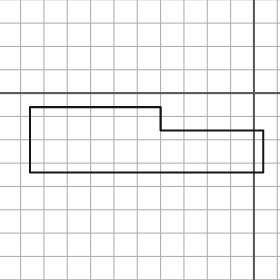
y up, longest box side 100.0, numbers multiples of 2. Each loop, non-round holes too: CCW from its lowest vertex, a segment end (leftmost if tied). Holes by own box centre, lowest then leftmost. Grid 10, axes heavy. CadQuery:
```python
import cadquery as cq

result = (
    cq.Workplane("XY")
    .moveTo(-96.0, -34.0)
    .lineTo(4.0, -34.0)
    .lineTo(4.0, -16.0)
    .lineTo(-40.0, -16.0)
    .lineTo(-40.0, -6.0)
    .lineTo(-96.0, -6.0)
    .close()
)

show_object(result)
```